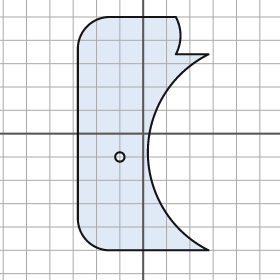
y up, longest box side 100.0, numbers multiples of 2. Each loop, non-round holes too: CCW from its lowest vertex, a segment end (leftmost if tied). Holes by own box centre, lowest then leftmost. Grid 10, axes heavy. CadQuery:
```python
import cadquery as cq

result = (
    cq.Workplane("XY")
    .moveTo(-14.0, -50.0)
    .lineTo(28.0, -50.0)
    .threePointArc((2.0, -8.0), (28.0, 34.0))
    .lineTo(14.0, 34.0)
    .threePointArc((16.0, 42.0), (14.0, 50.0))
    .lineTo(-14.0, 50.0)
    .threePointArc((-24.0, 46.0), (-28.0, 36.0))
    .lineTo(-28.0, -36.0)
    .threePointArc((-24.0, -46.0), (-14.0, -50.0))
    .close()
    .moveTo(-10.0, -10.0)
    .circle(2.0)
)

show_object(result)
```